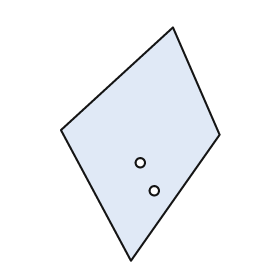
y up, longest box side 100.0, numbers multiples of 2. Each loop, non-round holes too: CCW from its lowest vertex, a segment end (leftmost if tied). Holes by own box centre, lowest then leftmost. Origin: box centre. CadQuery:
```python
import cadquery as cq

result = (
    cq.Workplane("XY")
    .moveTo(-4.0, -50.0)
    .lineTo(34.0, 4.0)
    .lineTo(14.0, 50.0)
    .lineTo(-34.0, 6.0)
    .close()
    .moveTo(6.0, -20.0)
    .circle(2.0)
    .moveTo(0.0, -8.0)
    .circle(2.0)
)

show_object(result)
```